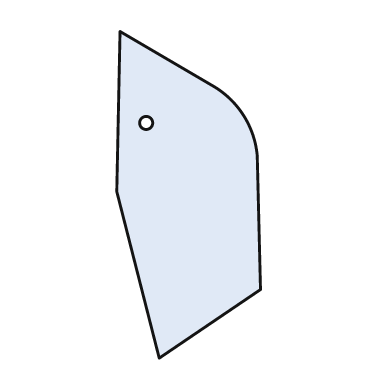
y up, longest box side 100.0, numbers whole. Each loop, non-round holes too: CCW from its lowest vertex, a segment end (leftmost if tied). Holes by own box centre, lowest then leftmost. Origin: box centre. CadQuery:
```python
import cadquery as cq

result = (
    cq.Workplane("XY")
    .moveTo(-9.0, -50.0)
    .lineTo(22.0, -29.0)
    .lineTo(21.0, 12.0)
    .threePointArc((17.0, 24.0), (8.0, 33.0))
    .lineTo(-21.0, 50.0)
    .lineTo(-22.0, 1.0)
    .close()
    .moveTo(-13.0, 22.0)
    .circle(2.0)
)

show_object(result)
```